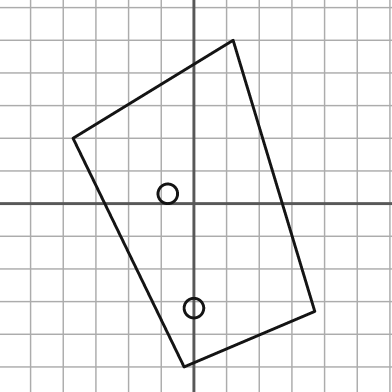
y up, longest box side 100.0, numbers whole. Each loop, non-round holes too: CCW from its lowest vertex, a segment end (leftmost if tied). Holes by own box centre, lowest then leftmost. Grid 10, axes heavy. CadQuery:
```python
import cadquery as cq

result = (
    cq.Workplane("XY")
    .moveTo(-3.0, -50.0)
    .lineTo(37.0, -33.0)
    .lineTo(12.0, 50.0)
    .lineTo(-37.0, 20.0)
    .close()
    .moveTo(0.0, -32.0)
    .circle(3.0)
    .moveTo(-8.0, 3.0)
    .circle(3.0)
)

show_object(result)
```